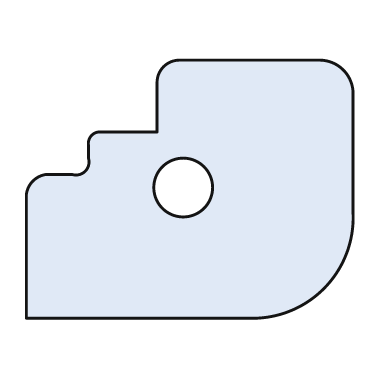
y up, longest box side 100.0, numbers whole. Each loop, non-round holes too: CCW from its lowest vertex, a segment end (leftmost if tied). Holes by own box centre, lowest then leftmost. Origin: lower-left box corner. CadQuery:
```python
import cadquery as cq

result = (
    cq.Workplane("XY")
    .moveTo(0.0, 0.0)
    .lineTo(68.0, 0.0)
    .threePointArc((91.0, 9.0), (100.0, 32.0))
    .lineTo(100.0, 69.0)
    .threePointArc((97.0, 76.0), (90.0, 79.0))
    .lineTo(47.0, 79.0)
    .threePointArc((42.0, 77.0), (40.0, 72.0))
    .lineTo(40.0, 57.0)
    .lineTo(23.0, 57.0)
    .threePointArc((20.0, 56.0), (19.0, 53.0))
    .lineTo(19.0, 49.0)
    .threePointArc((18.0, 45.0), (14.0, 44.0))
    .lineTo(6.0, 44.0)
    .threePointArc((2.0, 42.0), (0.0, 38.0))
    .close()
    .moveTo(48.0, 40.0)
    .circle(9.0)
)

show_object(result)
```